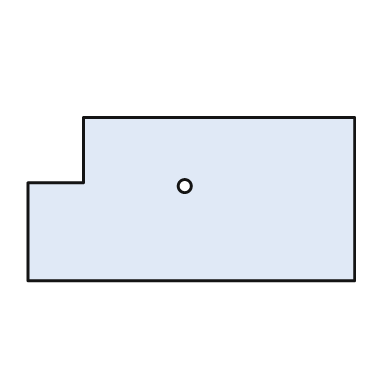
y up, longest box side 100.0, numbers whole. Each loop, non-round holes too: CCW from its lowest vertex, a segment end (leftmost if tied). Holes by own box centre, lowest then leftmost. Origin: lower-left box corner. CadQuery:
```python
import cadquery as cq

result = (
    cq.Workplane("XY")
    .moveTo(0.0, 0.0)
    .lineTo(100.0, 0.0)
    .lineTo(100.0, 50.0)
    .lineTo(17.0, 50.0)
    .lineTo(17.0, 30.0)
    .lineTo(0.0, 30.0)
    .close()
    .moveTo(48.0, 29.0)
    .circle(2.0)
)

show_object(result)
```